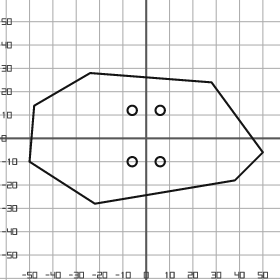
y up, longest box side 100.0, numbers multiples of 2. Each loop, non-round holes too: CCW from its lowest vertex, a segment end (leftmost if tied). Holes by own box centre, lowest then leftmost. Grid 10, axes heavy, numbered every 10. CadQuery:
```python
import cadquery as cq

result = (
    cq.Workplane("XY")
    .moveTo(-22.0, -28.0)
    .lineTo(38.0, -18.0)
    .lineTo(50.0, -6.0)
    .lineTo(28.0, 24.0)
    .lineTo(-24.0, 28.0)
    .lineTo(-48.0, 14.0)
    .lineTo(-50.0, -10.0)
    .close()
    .moveTo(-6.0, -10.0)
    .circle(2.0)
    .moveTo(6.0, -10.0)
    .circle(2.0)
    .moveTo(-6.0, 12.0)
    .circle(2.0)
    .moveTo(6.0, 12.0)
    .circle(2.0)
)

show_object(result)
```